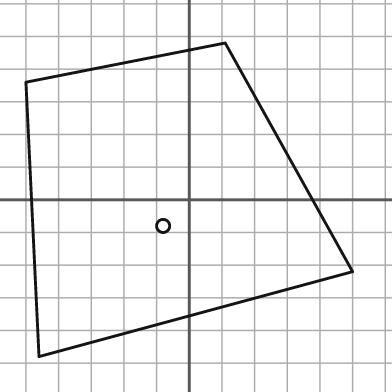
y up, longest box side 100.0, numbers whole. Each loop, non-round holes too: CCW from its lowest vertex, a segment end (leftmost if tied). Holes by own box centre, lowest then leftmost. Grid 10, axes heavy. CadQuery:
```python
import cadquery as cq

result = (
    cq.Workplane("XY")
    .moveTo(-46.0, -48.0)
    .lineTo(50.0, -22.0)
    .lineTo(11.0, 48.0)
    .lineTo(-50.0, 36.0)
    .close()
    .moveTo(-8.0, -8.0)
    .circle(2.0)
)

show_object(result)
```